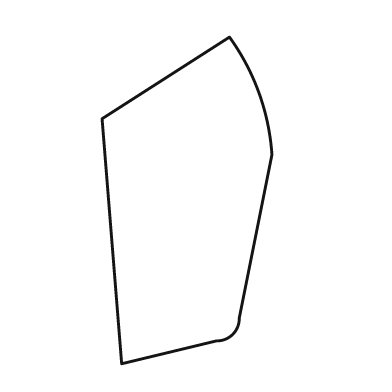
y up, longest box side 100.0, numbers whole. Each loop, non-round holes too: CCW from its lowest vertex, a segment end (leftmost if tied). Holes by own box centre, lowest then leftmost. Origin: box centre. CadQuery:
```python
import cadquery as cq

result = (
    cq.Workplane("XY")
    .moveTo(-20.0, -50.0)
    .lineTo(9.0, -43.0)
    .threePointArc((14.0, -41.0), (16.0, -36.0))
    .lineTo(26.0, 14.0)
    .threePointArc((22.0, 33.0), (13.0, 50.0))
    .lineTo(-26.0, 25.0)
    .close()
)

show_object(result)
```